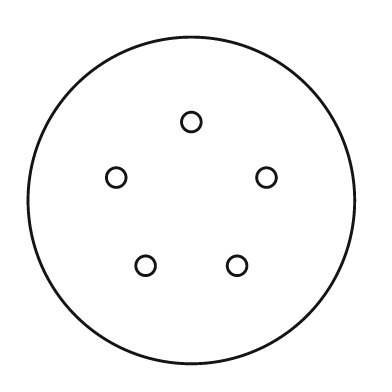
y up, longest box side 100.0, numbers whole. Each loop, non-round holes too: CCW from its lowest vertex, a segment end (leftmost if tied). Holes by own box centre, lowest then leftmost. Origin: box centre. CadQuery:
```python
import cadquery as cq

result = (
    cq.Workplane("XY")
    .moveTo(0.0, 0.0)
    .circle(50.0)
    .moveTo(-14.0, -20.0)
    .circle(3.0)
    .moveTo(14.0, -20.0)
    .circle(3.0)
    .moveTo(-23.0, 7.0)
    .circle(3.0)
    .moveTo(23.0, 7.0)
    .circle(3.0)
    .moveTo(0.0, 24.0)
    .circle(3.0)
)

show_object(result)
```